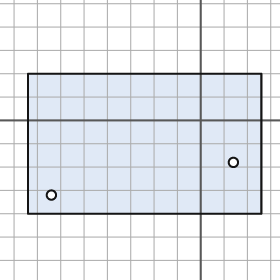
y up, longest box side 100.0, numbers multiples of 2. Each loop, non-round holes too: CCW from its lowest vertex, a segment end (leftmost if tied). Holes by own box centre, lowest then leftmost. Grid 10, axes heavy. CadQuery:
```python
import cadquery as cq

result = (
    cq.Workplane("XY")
    .moveTo(-74.0, -40.0)
    .lineTo(26.0, -40.0)
    .lineTo(26.0, 20.0)
    .lineTo(-74.0, 20.0)
    .close()
    .moveTo(-64.0, -32.0)
    .circle(2.0)
    .moveTo(14.0, -18.0)
    .circle(2.0)
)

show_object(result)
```